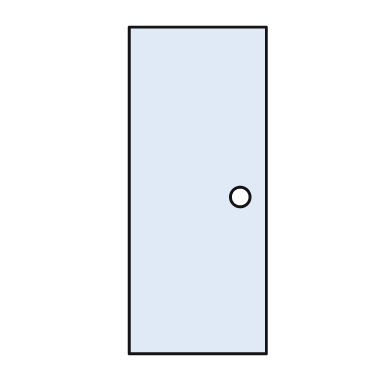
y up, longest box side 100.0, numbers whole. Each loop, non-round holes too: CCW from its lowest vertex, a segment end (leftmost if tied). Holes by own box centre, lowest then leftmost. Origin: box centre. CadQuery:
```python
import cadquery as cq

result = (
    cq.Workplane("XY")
    .moveTo(-21.0, -50.0)
    .lineTo(21.0, -50.0)
    .lineTo(21.0, 50.0)
    .lineTo(-21.0, 50.0)
    .close()
    .moveTo(13.0, -2.0)
    .circle(3.0)
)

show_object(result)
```